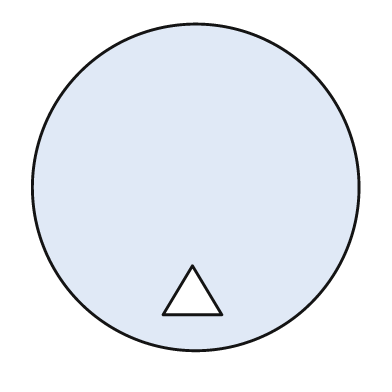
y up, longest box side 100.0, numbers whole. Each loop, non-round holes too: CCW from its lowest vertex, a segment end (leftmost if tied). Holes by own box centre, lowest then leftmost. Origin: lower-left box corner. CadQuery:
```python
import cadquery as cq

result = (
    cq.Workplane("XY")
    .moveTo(50.0, 50.0)
    .circle(50.0)
    .moveTo(40.0, 11.0)
    .lineTo(58.0, 11.0)
    .lineTo(49.0, 26.0)
    .close()
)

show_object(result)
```